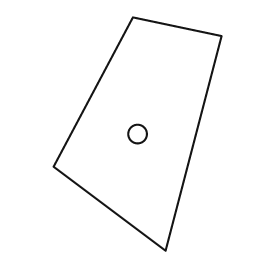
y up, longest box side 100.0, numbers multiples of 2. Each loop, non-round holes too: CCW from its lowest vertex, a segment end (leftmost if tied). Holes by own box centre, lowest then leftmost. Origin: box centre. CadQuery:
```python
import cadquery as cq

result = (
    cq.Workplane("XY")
    .moveTo(12.0, -50.0)
    .lineTo(36.0, 42.0)
    .lineTo(-2.0, 50.0)
    .lineTo(-36.0, -14.0)
    .close()
    .moveTo(0.0, 0.0)
    .circle(4.0)
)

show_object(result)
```